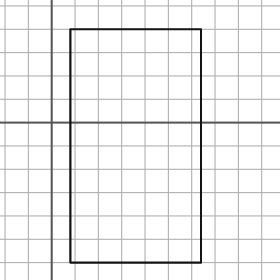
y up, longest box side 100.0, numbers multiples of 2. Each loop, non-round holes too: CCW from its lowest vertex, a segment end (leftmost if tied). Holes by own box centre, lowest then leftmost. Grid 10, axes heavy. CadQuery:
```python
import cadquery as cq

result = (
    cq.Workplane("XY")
    .moveTo(8.0, -60.0)
    .lineTo(64.0, -60.0)
    .lineTo(64.0, 40.0)
    .lineTo(8.0, 40.0)
    .close()
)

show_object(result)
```